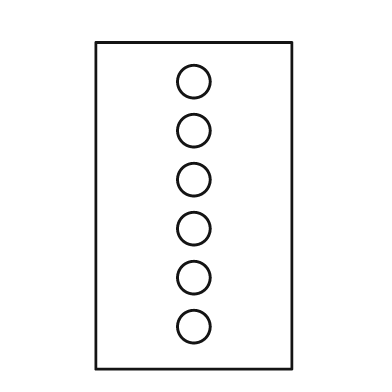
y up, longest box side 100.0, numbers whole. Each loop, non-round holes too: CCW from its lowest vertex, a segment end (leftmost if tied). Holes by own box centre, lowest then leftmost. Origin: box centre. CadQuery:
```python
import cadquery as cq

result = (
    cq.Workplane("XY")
    .moveTo(-30.0, -50.0)
    .lineTo(30.0, -50.0)
    .lineTo(30.0, 50.0)
    .lineTo(-30.0, 50.0)
    .close()
    .moveTo(0.0, -37.0)
    .circle(5.0)
    .moveTo(0.0, -22.0)
    .circle(5.0)
    .moveTo(0.0, -7.0)
    .circle(5.0)
    .moveTo(0.0, 8.0)
    .circle(5.0)
    .moveTo(0.0, 23.0)
    .circle(5.0)
    .moveTo(0.0, 38.0)
    .circle(5.0)
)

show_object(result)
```